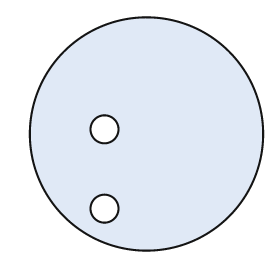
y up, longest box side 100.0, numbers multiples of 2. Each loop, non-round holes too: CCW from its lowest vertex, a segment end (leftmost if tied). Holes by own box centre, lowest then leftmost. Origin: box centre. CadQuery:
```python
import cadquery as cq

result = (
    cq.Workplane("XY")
    .moveTo(0.0, 0.0)
    .circle(50.0)
    .moveTo(-18.0, -32.0)
    .circle(6.0)
    .moveTo(-18.0, 2.0)
    .circle(6.0)
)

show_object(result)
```